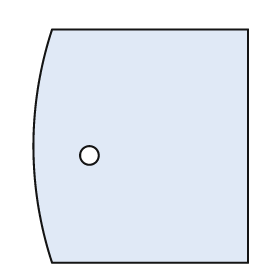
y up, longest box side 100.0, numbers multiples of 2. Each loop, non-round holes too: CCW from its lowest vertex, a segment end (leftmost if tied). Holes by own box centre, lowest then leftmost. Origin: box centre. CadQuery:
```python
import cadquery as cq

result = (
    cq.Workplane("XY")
    .moveTo(-38.0, -50.0)
    .lineTo(46.0, -50.0)
    .lineTo(46.0, 50.0)
    .lineTo(-38.0, 50.0)
    .threePointArc((-46.0, 0.0), (-38.0, -50.0))
    .close()
    .moveTo(-22.0, -4.0)
    .circle(4.0)
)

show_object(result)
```